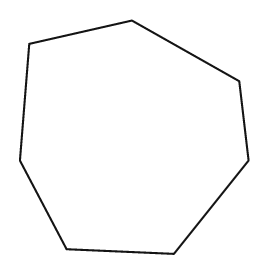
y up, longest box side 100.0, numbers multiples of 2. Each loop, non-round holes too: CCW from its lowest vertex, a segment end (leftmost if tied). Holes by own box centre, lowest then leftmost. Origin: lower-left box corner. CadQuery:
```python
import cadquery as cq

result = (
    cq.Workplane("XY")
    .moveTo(66.0, 0.0)
    .lineTo(98.0, 40.0)
    .lineTo(94.0, 74.0)
    .lineTo(48.0, 100.0)
    .lineTo(4.0, 90.0)
    .lineTo(0.0, 40.0)
    .lineTo(20.0, 2.0)
    .close()
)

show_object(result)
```